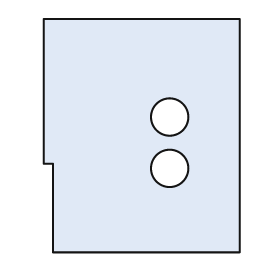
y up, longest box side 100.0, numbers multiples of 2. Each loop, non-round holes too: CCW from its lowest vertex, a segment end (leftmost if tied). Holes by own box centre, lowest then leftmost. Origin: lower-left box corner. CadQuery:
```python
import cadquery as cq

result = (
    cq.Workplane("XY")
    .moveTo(4.0, 0.0)
    .lineTo(84.0, 0.0)
    .lineTo(84.0, 100.0)
    .lineTo(0.0, 100.0)
    .lineTo(0.0, 38.0)
    .lineTo(4.0, 38.0)
    .close()
    .moveTo(54.0, 36.0)
    .circle(8.0)
    .moveTo(54.0, 58.0)
    .circle(8.0)
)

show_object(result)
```